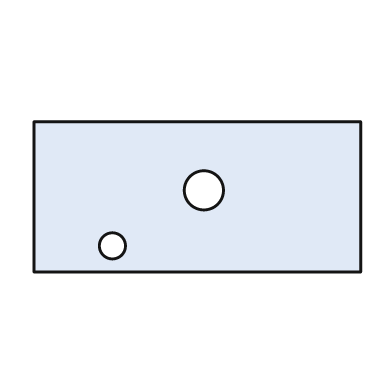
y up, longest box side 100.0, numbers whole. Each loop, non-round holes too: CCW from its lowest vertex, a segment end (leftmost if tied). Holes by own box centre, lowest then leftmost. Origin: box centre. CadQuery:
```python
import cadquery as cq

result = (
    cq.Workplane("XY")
    .moveTo(-50.0, -23.0)
    .lineTo(50.0, -23.0)
    .lineTo(50.0, 23.0)
    .lineTo(-50.0, 23.0)
    .close()
    .moveTo(-26.0, -15.0)
    .circle(4.0)
    .moveTo(2.0, 2.0)
    .circle(6.0)
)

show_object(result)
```